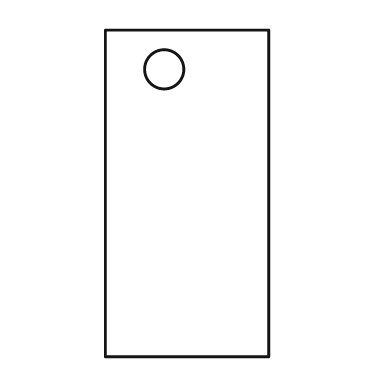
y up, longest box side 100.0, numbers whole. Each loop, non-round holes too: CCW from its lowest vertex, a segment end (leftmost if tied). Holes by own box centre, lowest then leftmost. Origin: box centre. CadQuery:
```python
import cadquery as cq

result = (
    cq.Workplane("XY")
    .moveTo(-25.0, -50.0)
    .lineTo(25.0, -50.0)
    .lineTo(25.0, 50.0)
    .lineTo(-25.0, 50.0)
    .close()
    .moveTo(-7.0, 38.0)
    .circle(6.0)
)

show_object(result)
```